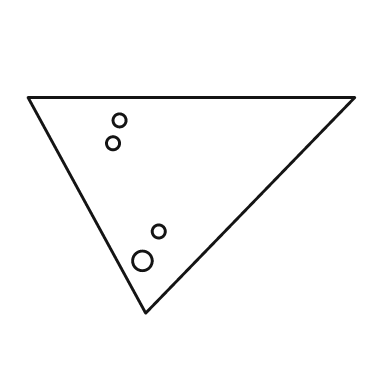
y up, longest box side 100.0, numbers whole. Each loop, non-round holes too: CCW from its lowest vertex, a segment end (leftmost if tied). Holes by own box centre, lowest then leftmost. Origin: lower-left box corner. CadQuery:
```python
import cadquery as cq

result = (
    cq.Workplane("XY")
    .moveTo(36.0, 0.0)
    .lineTo(100.0, 66.0)
    .lineTo(0.0, 66.0)
    .close()
    .moveTo(35.0, 16.0)
    .circle(3.0)
    .moveTo(40.0, 25.0)
    .circle(2.0)
    .moveTo(26.0, 52.0)
    .circle(2.0)
    .moveTo(28.0, 59.0)
    .circle(2.0)
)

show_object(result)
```